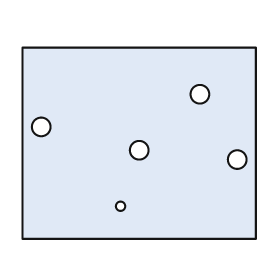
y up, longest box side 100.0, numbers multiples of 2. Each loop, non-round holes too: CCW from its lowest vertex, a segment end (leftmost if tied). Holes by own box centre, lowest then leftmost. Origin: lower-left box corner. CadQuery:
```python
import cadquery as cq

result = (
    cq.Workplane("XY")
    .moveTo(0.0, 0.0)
    .lineTo(100.0, 0.0)
    .lineTo(100.0, 82.0)
    .lineTo(0.0, 82.0)
    .close()
    .moveTo(42.0, 14.0)
    .circle(2.0)
    .moveTo(92.0, 34.0)
    .circle(4.0)
    .moveTo(50.0, 38.0)
    .circle(4.0)
    .moveTo(8.0, 48.0)
    .circle(4.0)
    .moveTo(76.0, 62.0)
    .circle(4.0)
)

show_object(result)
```